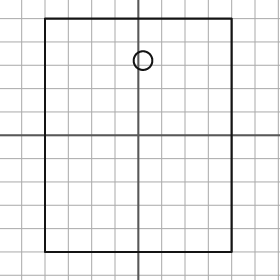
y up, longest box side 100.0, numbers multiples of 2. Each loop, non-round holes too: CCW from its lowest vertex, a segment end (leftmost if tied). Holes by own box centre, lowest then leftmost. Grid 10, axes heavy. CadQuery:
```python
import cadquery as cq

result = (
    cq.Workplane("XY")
    .moveTo(-40.0, -50.0)
    .lineTo(40.0, -50.0)
    .lineTo(40.0, 50.0)
    .lineTo(-40.0, 50.0)
    .close()
    .moveTo(2.0, 32.0)
    .circle(4.0)
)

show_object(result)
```